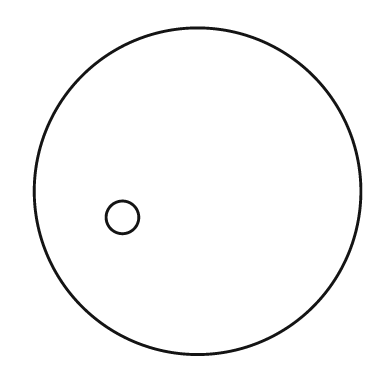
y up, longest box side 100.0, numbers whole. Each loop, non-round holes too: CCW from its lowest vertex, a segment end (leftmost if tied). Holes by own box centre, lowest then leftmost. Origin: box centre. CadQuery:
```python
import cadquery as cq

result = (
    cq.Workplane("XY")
    .moveTo(0.0, 0.0)
    .circle(50.0)
    .moveTo(-23.0, -8.0)
    .circle(5.0)
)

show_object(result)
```